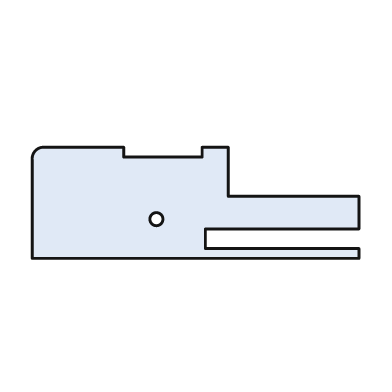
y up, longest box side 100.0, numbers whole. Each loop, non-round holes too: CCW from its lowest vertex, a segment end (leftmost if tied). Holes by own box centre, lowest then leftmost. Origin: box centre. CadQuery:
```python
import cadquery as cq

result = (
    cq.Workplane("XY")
    .moveTo(-50.0, -17.0)
    .lineTo(50.0, -17.0)
    .lineTo(50.0, -14.0)
    .lineTo(3.0, -14.0)
    .lineTo(3.0, -8.0)
    .lineTo(50.0, -8.0)
    .lineTo(50.0, 2.0)
    .lineTo(10.0, 2.0)
    .lineTo(10.0, 17.0)
    .lineTo(2.0, 17.0)
    .lineTo(2.0, 14.0)
    .lineTo(-22.0, 14.0)
    .lineTo(-22.0, 17.0)
    .lineTo(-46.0, 17.0)
    .threePointArc((-49.0, 16.0), (-50.0, 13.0))
    .close()
    .moveTo(-12.0, -5.0)
    .circle(2.0)
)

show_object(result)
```